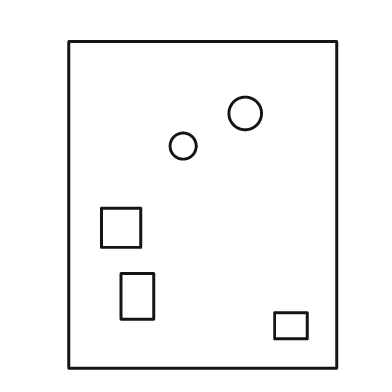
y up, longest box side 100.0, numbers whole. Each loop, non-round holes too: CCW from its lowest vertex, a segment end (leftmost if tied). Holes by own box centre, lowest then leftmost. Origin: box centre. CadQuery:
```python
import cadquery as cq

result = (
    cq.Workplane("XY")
    .moveTo(-41.0, -50.0)
    .lineTo(41.0, -50.0)
    .lineTo(41.0, 50.0)
    .lineTo(-41.0, 50.0)
    .close()
    .moveTo(22.0, -41.0)
    .lineTo(32.0, -41.0)
    .lineTo(32.0, -33.0)
    .lineTo(22.0, -33.0)
    .close()
    .moveTo(-25.0, -35.0)
    .lineTo(-15.0, -35.0)
    .lineTo(-15.0, -21.0)
    .lineTo(-25.0, -21.0)
    .close()
    .moveTo(-31.0, -13.0)
    .lineTo(-19.0, -13.0)
    .lineTo(-19.0, -1.0)
    .lineTo(-31.0, -1.0)
    .close()
    .moveTo(-6.0, 18.0)
    .circle(4.0)
    .moveTo(13.0, 28.0)
    .circle(5.0)
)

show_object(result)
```